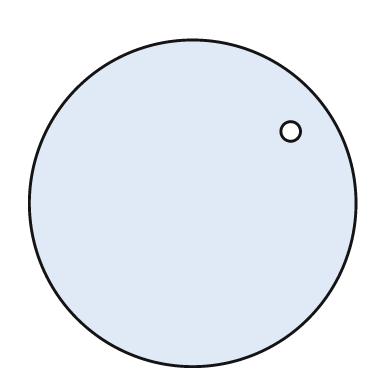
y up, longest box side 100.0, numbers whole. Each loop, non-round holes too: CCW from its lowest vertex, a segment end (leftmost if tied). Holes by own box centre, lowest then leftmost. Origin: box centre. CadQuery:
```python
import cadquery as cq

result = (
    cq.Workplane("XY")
    .moveTo(0.0, 0.0)
    .circle(50.0)
    .moveTo(30.0, 22.0)
    .circle(3.0)
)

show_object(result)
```